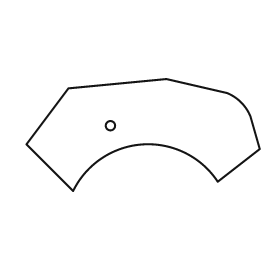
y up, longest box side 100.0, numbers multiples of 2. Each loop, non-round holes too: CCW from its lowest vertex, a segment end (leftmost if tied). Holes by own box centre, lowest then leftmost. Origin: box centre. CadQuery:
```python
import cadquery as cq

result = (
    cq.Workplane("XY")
    .moveTo(-30.0, -24.0)
    .threePointArc((0.0, -4.0), (32.0, -20.0))
    .lineTo(50.0, -6.0)
    .lineTo(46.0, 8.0)
    .threePointArc((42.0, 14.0), (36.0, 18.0))
    .lineTo(10.0, 24.0)
    .lineTo(-32.0, 20.0)
    .lineTo(-50.0, -4.0)
    .close()
    .moveTo(-14.0, 4.0)
    .circle(2.0)
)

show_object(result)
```